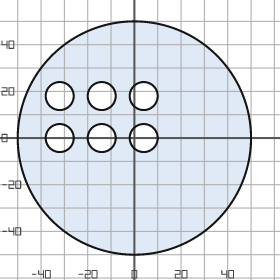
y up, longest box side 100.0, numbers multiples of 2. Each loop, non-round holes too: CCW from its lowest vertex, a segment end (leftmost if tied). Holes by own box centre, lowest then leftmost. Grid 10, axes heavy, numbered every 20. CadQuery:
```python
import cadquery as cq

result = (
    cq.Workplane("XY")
    .moveTo(0.0, 0.0)
    .circle(50.0)
    .moveTo(-32.0, 0.0)
    .circle(6.0)
    .moveTo(-14.0, 0.0)
    .circle(6.0)
    .moveTo(4.0, 0.0)
    .circle(6.0)
    .moveTo(-32.0, 18.0)
    .circle(6.0)
    .moveTo(-14.0, 18.0)
    .circle(6.0)
    .moveTo(4.0, 18.0)
    .circle(6.0)
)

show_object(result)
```